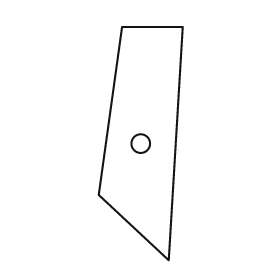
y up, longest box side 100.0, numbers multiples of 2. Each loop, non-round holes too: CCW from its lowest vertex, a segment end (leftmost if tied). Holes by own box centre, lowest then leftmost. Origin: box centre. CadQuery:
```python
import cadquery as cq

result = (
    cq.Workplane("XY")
    .moveTo(12.0, -50.0)
    .lineTo(18.0, 50.0)
    .lineTo(-8.0, 50.0)
    .lineTo(-18.0, -22.0)
    .close()
    .moveTo(0.0, 0.0)
    .circle(4.0)
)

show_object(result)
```